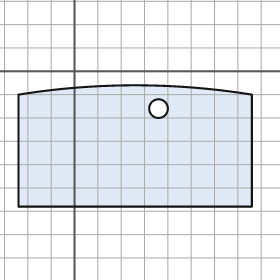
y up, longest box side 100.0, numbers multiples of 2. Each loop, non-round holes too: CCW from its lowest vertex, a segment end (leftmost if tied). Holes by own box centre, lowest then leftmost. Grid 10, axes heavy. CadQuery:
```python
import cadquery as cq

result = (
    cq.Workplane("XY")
    .moveTo(-24.0, -58.0)
    .lineTo(76.0, -58.0)
    .lineTo(76.0, -10.0)
    .threePointArc((26.0, -6.0), (-24.0, -10.0))
    .close()
    .moveTo(36.0, -16.0)
    .circle(4.0)
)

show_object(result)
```